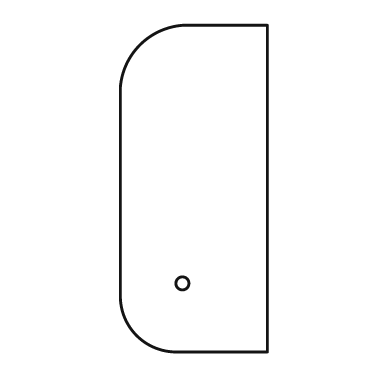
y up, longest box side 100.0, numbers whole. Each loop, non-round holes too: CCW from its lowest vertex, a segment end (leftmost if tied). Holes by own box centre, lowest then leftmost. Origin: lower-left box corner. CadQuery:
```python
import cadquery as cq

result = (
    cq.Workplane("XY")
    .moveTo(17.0, 0.0)
    .lineTo(45.0, 0.0)
    .lineTo(45.0, 100.0)
    .lineTo(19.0, 100.0)
    .threePointArc((6.0, 94.0), (0.0, 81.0))
    .lineTo(0.0, 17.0)
    .threePointArc((5.0, 5.0), (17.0, 0.0))
    .close()
    .moveTo(19.0, 21.0)
    .circle(2.0)
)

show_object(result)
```